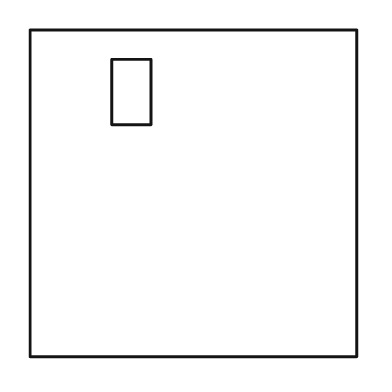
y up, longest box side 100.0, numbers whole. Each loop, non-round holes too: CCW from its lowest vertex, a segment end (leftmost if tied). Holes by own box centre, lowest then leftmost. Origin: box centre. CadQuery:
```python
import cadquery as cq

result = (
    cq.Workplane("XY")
    .moveTo(-50.0, -50.0)
    .lineTo(50.0, -50.0)
    .lineTo(50.0, 50.0)
    .lineTo(-50.0, 50.0)
    .close()
    .moveTo(-25.0, 21.0)
    .lineTo(-13.0, 21.0)
    .lineTo(-13.0, 41.0)
    .lineTo(-25.0, 41.0)
    .close()
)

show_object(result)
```